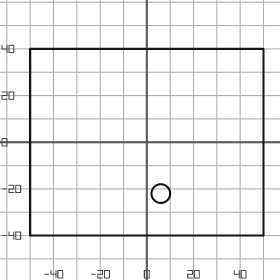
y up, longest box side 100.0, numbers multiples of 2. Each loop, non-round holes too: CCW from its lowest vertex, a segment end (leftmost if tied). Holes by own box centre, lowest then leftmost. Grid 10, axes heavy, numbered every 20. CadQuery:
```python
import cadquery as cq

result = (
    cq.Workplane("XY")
    .moveTo(-50.0, -40.0)
    .lineTo(50.0, -40.0)
    .lineTo(50.0, 40.0)
    .lineTo(-50.0, 40.0)
    .close()
    .moveTo(6.0, -22.0)
    .circle(4.0)
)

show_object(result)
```